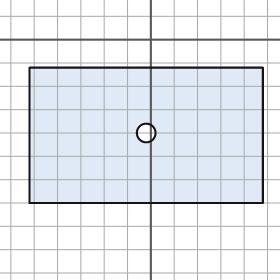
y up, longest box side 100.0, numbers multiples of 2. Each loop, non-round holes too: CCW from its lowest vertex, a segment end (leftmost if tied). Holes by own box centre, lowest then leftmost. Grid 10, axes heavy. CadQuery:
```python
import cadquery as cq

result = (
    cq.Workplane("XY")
    .moveTo(-52.0, -70.0)
    .lineTo(48.0, -70.0)
    .lineTo(48.0, -12.0)
    .lineTo(-52.0, -12.0)
    .close()
    .moveTo(-2.0, -40.0)
    .circle(4.0)
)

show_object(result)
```